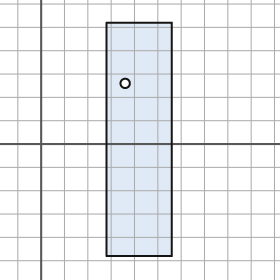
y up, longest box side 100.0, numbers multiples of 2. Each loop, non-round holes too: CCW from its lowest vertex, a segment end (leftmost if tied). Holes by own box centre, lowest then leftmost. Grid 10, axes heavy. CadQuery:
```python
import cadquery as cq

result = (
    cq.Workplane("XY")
    .moveTo(28.0, -48.0)
    .lineTo(56.0, -48.0)
    .lineTo(56.0, 52.0)
    .lineTo(28.0, 52.0)
    .close()
    .moveTo(36.0, 26.0)
    .circle(2.0)
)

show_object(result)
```